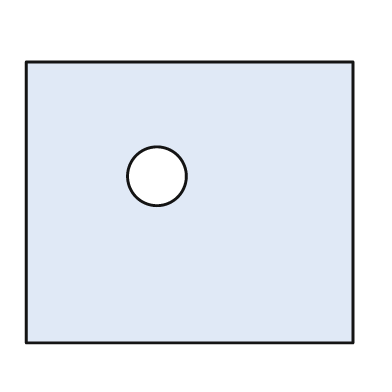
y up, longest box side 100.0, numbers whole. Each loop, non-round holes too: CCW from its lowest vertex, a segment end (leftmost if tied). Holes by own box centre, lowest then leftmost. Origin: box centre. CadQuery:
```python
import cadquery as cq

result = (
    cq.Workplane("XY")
    .moveTo(-50.0, -43.0)
    .lineTo(50.0, -43.0)
    .lineTo(50.0, 43.0)
    .lineTo(-50.0, 43.0)
    .close()
    .moveTo(-10.0, 8.0)
    .circle(9.0)
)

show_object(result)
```